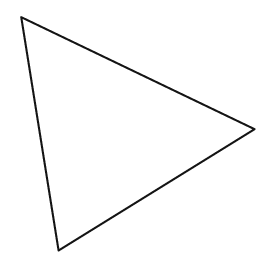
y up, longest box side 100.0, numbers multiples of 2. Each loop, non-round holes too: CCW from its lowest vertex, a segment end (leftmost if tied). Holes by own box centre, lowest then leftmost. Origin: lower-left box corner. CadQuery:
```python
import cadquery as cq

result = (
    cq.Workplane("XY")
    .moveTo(16.0, 0.0)
    .lineTo(100.0, 52.0)
    .lineTo(0.0, 100.0)
    .close()
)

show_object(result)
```